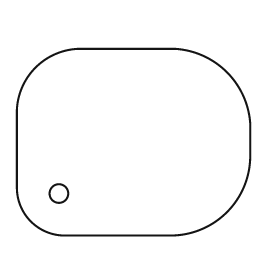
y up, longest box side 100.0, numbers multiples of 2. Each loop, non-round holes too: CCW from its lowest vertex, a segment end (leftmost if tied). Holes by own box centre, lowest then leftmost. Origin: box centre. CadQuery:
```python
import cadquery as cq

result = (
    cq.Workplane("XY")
    .moveTo(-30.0, -40.0)
    .lineTo(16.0, -40.0)
    .threePointArc((40.0, -30.0), (50.0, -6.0))
    .lineTo(50.0, 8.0)
    .threePointArc((40.0, 30.0), (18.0, 40.0))
    .lineTo(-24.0, 40.0)
    .threePointArc((-42.0, 32.0), (-50.0, 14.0))
    .lineTo(-50.0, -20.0)
    .threePointArc((-44.0, -34.0), (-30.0, -40.0))
    .close()
    .moveTo(-32.0, -22.0)
    .circle(4.0)
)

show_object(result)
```